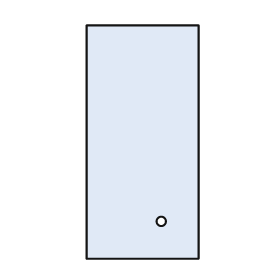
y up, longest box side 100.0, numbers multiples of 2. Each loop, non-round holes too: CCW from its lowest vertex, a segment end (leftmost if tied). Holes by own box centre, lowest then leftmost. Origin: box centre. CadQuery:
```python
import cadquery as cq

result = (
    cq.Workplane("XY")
    .moveTo(-24.0, -50.0)
    .lineTo(24.0, -50.0)
    .lineTo(24.0, 50.0)
    .lineTo(-24.0, 50.0)
    .close()
    .moveTo(8.0, -34.0)
    .circle(2.0)
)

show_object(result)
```